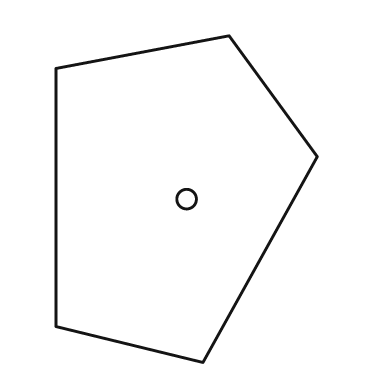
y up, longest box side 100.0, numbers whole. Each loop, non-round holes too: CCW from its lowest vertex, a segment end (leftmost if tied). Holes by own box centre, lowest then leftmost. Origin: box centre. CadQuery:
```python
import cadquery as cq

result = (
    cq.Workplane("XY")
    .moveTo(5.0, -50.0)
    .lineTo(40.0, 13.0)
    .lineTo(13.0, 50.0)
    .lineTo(-40.0, 40.0)
    .lineTo(-40.0, -39.0)
    .close()
    .moveTo(0.0, 0.0)
    .circle(3.0)
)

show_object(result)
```